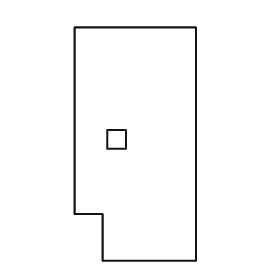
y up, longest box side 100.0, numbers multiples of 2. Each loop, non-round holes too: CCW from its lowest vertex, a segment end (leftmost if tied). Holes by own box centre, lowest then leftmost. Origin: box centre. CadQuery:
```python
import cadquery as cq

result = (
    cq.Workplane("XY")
    .moveTo(-14.0, -50.0)
    .lineTo(26.0, -50.0)
    .lineTo(26.0, 50.0)
    .lineTo(-26.0, 50.0)
    .lineTo(-26.0, -30.0)
    .lineTo(-14.0, -30.0)
    .close()
    .moveTo(-12.0, -2.0)
    .lineTo(-4.0, -2.0)
    .lineTo(-4.0, 6.0)
    .lineTo(-12.0, 6.0)
    .close()
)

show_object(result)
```